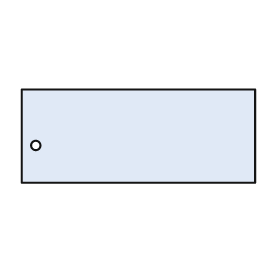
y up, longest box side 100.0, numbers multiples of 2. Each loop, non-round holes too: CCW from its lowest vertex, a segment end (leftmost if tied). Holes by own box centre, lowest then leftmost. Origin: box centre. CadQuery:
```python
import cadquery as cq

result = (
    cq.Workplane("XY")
    .moveTo(-50.0, -20.0)
    .lineTo(50.0, -20.0)
    .lineTo(50.0, 20.0)
    .lineTo(-50.0, 20.0)
    .close()
    .moveTo(-44.0, -4.0)
    .circle(2.0)
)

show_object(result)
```